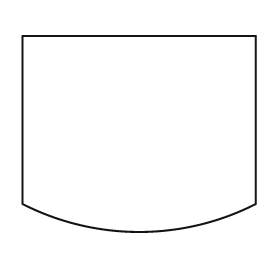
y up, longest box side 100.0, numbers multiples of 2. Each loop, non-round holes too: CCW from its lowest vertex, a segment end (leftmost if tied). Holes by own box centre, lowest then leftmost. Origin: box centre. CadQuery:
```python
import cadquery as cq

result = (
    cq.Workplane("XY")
    .moveTo(-50.0, -30.0)
    .threePointArc((0.0, -42.0), (50.0, -30.0))
    .lineTo(50.0, 42.0)
    .lineTo(-50.0, 42.0)
    .close()
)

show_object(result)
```